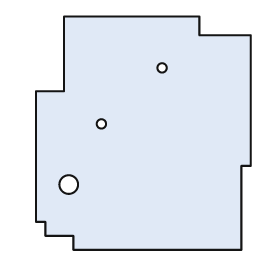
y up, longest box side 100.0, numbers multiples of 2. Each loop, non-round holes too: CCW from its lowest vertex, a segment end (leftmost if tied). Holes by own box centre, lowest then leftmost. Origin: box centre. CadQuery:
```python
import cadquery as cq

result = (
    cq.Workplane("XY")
    .moveTo(-30.0, -50.0)
    .lineTo(42.0, -50.0)
    .lineTo(42.0, -14.0)
    .lineTo(46.0, -14.0)
    .lineTo(46.0, 42.0)
    .lineTo(24.0, 42.0)
    .lineTo(24.0, 50.0)
    .lineTo(-34.0, 50.0)
    .lineTo(-34.0, 18.0)
    .lineTo(-46.0, 18.0)
    .lineTo(-46.0, -38.0)
    .lineTo(-42.0, -38.0)
    .lineTo(-42.0, -44.0)
    .lineTo(-30.0, -44.0)
    .close()
    .moveTo(-32.0, -22.0)
    .circle(4.0)
    .moveTo(-18.0, 4.0)
    .circle(2.0)
    .moveTo(8.0, 28.0)
    .circle(2.0)
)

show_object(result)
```